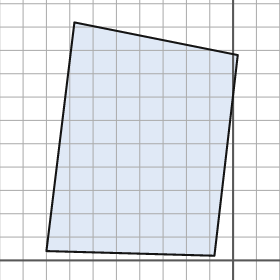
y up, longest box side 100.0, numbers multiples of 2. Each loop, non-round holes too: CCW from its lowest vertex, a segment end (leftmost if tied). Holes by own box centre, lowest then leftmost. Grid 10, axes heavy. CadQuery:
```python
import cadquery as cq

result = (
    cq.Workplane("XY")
    .moveTo(-8.0, 2.0)
    .lineTo(2.0, 88.0)
    .lineTo(-68.0, 102.0)
    .lineTo(-80.0, 4.0)
    .close()
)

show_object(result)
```